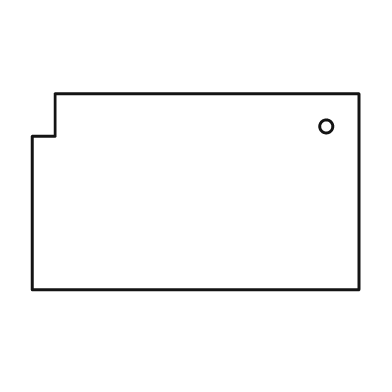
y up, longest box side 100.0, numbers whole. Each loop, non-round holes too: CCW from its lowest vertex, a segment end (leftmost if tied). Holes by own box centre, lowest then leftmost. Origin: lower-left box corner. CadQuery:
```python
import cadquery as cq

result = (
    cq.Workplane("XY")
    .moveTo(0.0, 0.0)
    .lineTo(100.0, 0.0)
    .lineTo(100.0, 60.0)
    .lineTo(7.0, 60.0)
    .lineTo(7.0, 47.0)
    .lineTo(0.0, 47.0)
    .close()
    .moveTo(90.0, 50.0)
    .circle(2.0)
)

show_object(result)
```